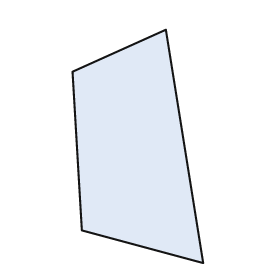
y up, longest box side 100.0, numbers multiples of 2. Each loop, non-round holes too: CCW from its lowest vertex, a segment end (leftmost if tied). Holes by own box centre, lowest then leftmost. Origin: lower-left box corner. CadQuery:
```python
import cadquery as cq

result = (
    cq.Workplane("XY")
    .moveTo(56.0, 0.0)
    .lineTo(40.0, 100.0)
    .lineTo(0.0, 82.0)
    .lineTo(4.0, 14.0)
    .close()
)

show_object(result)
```